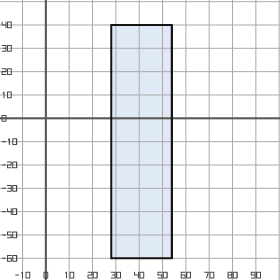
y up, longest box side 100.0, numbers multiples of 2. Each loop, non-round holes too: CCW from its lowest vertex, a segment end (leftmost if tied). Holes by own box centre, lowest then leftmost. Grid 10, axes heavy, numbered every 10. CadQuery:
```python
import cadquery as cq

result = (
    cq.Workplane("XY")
    .moveTo(28.0, -60.0)
    .lineTo(54.0, -60.0)
    .lineTo(54.0, 40.0)
    .lineTo(28.0, 40.0)
    .close()
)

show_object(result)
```